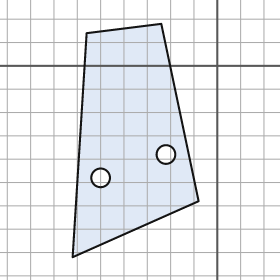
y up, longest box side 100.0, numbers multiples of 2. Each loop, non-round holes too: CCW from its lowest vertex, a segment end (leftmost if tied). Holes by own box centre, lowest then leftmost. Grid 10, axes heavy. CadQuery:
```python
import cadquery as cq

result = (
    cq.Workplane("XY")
    .moveTo(-62.0, -82.0)
    .lineTo(-8.0, -58.0)
    .lineTo(-24.0, 18.0)
    .lineTo(-56.0, 14.0)
    .close()
    .moveTo(-50.0, -48.0)
    .circle(4.0)
    .moveTo(-22.0, -38.0)
    .circle(4.0)
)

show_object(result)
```